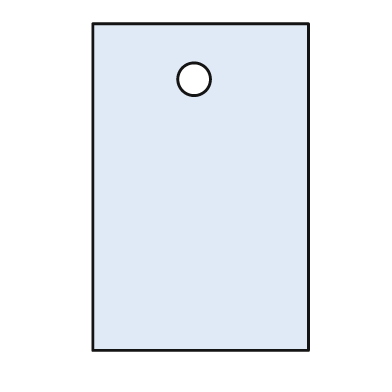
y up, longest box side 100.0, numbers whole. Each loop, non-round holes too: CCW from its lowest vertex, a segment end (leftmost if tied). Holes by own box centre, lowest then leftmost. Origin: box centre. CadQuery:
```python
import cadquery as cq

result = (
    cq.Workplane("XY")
    .moveTo(-33.0, -50.0)
    .lineTo(33.0, -50.0)
    .lineTo(33.0, 50.0)
    .lineTo(-33.0, 50.0)
    .close()
    .moveTo(-2.0, 33.0)
    .circle(5.0)
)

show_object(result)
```